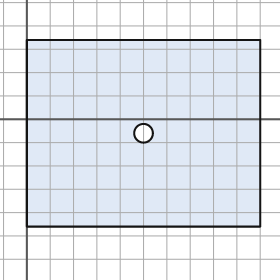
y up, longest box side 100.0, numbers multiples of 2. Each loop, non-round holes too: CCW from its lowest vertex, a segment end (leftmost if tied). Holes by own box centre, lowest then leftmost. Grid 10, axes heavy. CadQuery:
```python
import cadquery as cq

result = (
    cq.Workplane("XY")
    .moveTo(0.0, -46.0)
    .lineTo(100.0, -46.0)
    .lineTo(100.0, 34.0)
    .lineTo(0.0, 34.0)
    .close()
    .moveTo(50.0, -6.0)
    .circle(4.0)
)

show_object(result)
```